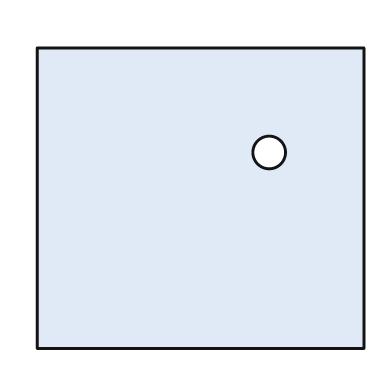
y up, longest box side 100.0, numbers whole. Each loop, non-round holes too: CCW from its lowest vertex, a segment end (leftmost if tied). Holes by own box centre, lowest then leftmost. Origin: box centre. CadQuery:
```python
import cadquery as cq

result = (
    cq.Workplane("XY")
    .moveTo(-50.0, -46.0)
    .lineTo(50.0, -46.0)
    .lineTo(50.0, 46.0)
    .lineTo(-50.0, 46.0)
    .close()
    .moveTo(21.0, 14.0)
    .circle(5.0)
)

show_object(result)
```